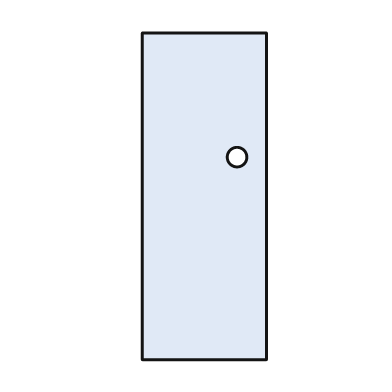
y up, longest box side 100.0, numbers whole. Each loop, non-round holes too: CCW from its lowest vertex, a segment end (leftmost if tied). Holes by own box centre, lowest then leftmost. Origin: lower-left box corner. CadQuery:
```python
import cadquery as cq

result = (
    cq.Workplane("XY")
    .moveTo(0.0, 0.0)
    .lineTo(38.0, 0.0)
    .lineTo(38.0, 100.0)
    .lineTo(0.0, 100.0)
    .close()
    .moveTo(29.0, 62.0)
    .circle(3.0)
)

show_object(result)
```